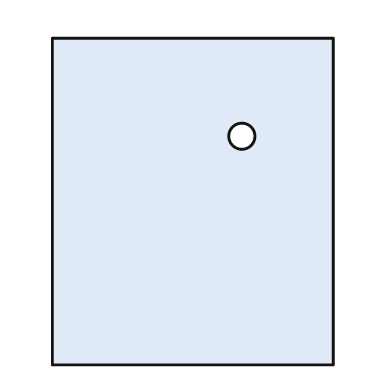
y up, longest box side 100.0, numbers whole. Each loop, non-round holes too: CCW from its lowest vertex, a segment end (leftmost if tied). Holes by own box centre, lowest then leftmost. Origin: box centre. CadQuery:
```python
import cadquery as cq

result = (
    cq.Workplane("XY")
    .moveTo(-43.0, -50.0)
    .lineTo(43.0, -50.0)
    .lineTo(43.0, 50.0)
    .lineTo(-43.0, 50.0)
    .close()
    .moveTo(15.0, 20.0)
    .circle(4.0)
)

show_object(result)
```